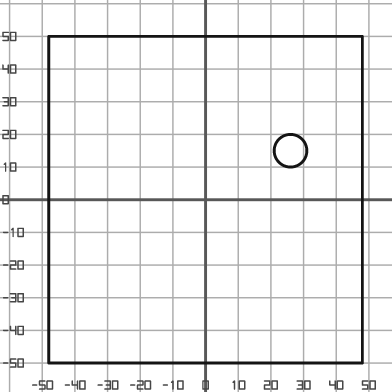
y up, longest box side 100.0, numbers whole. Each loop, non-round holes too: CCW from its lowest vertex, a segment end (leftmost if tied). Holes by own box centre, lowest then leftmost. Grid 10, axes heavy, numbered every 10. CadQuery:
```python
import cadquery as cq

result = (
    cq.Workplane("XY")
    .moveTo(-48.0, -50.0)
    .lineTo(48.0, -50.0)
    .lineTo(48.0, 50.0)
    .lineTo(-48.0, 50.0)
    .close()
    .moveTo(26.0, 15.0)
    .circle(5.0)
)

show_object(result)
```